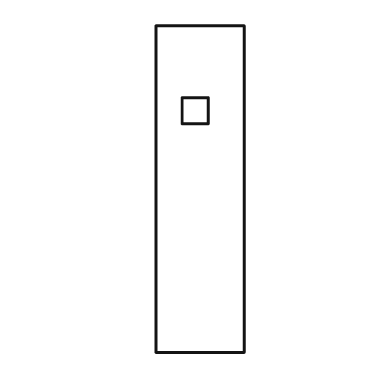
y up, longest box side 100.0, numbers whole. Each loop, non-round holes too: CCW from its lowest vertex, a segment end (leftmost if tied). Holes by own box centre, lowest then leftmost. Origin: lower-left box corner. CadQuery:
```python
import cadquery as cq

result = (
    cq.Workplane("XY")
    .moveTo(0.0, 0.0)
    .lineTo(27.0, 0.0)
    .lineTo(27.0, 100.0)
    .lineTo(0.0, 100.0)
    .close()
    .moveTo(8.0, 70.0)
    .lineTo(16.0, 70.0)
    .lineTo(16.0, 78.0)
    .lineTo(8.0, 78.0)
    .close()
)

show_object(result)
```